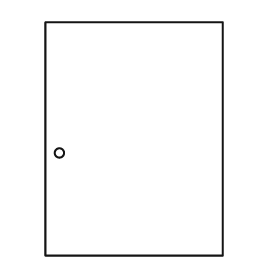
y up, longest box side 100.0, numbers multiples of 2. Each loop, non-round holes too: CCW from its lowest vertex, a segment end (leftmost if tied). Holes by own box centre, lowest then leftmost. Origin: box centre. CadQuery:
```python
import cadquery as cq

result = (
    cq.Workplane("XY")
    .moveTo(-38.0, -50.0)
    .lineTo(38.0, -50.0)
    .lineTo(38.0, 50.0)
    .lineTo(-38.0, 50.0)
    .close()
    .moveTo(-32.0, -6.0)
    .circle(2.0)
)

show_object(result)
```